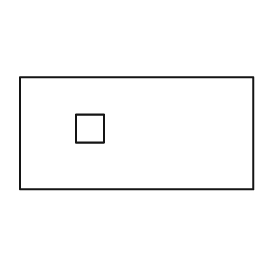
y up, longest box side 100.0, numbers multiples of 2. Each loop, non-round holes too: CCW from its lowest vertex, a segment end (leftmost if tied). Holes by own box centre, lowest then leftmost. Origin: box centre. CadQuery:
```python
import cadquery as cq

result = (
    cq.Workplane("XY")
    .moveTo(-50.0, -24.0)
    .lineTo(50.0, -24.0)
    .lineTo(50.0, 24.0)
    .lineTo(-50.0, 24.0)
    .close()
    .moveTo(-26.0, -4.0)
    .lineTo(-14.0, -4.0)
    .lineTo(-14.0, 8.0)
    .lineTo(-26.0, 8.0)
    .close()
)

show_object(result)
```